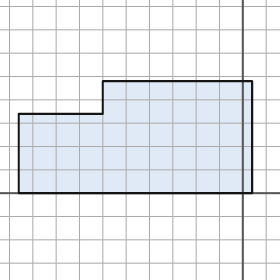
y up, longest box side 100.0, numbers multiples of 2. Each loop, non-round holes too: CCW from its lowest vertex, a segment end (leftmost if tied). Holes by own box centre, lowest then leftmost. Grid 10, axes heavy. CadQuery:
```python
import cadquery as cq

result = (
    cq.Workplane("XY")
    .moveTo(-96.0, 0.0)
    .lineTo(4.0, 0.0)
    .lineTo(4.0, 48.0)
    .lineTo(-60.0, 48.0)
    .lineTo(-60.0, 34.0)
    .lineTo(-96.0, 34.0)
    .close()
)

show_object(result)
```